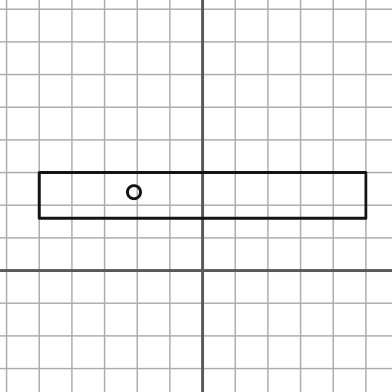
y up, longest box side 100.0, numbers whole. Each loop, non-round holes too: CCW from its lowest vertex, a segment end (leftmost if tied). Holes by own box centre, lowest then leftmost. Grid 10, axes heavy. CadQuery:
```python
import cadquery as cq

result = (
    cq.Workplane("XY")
    .moveTo(-50.0, 16.0)
    .lineTo(50.0, 16.0)
    .lineTo(50.0, 30.0)
    .lineTo(-50.0, 30.0)
    .close()
    .moveTo(-21.0, 24.0)
    .circle(2.0)
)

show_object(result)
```